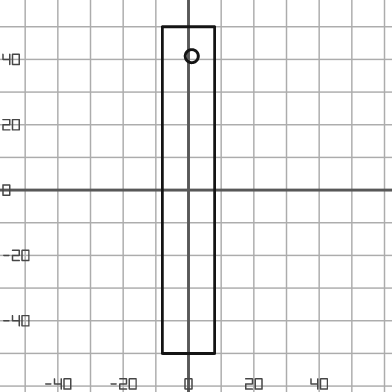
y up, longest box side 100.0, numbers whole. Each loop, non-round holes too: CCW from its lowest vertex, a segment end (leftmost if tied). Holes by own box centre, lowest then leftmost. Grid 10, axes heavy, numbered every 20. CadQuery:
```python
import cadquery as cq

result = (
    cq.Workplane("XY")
    .moveTo(-8.0, -50.0)
    .lineTo(8.0, -50.0)
    .lineTo(8.0, 50.0)
    .lineTo(-8.0, 50.0)
    .close()
    .moveTo(1.0, 41.0)
    .circle(2.0)
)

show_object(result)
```